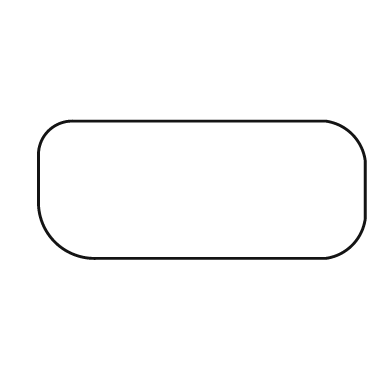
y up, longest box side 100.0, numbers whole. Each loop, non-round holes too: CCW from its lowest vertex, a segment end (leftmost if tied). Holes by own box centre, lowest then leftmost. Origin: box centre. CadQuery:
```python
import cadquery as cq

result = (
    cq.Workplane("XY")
    .moveTo(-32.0, -21.0)
    .lineTo(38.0, -21.0)
    .threePointArc((46.0, -17.0), (50.0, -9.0))
    .lineTo(50.0, 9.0)
    .threePointArc((46.0, 17.0), (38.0, 21.0))
    .lineTo(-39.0, 21.0)
    .threePointArc((-47.0, 18.0), (-50.0, 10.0))
    .lineTo(-50.0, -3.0)
    .threePointArc((-45.0, -16.0), (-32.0, -21.0))
    .close()
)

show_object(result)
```